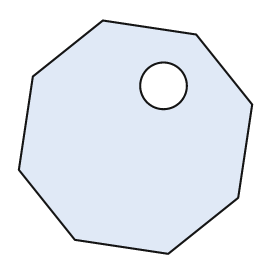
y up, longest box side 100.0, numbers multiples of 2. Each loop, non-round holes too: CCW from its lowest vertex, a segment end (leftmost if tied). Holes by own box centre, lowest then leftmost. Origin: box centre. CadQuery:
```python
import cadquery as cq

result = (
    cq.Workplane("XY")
    .moveTo(14.0, -50.0)
    .lineTo(44.0, -26.0)
    .lineTo(50.0, 14.0)
    .lineTo(26.0, 44.0)
    .lineTo(-14.0, 50.0)
    .lineTo(-44.0, 26.0)
    .lineTo(-50.0, -14.0)
    .lineTo(-26.0, -44.0)
    .close()
    .moveTo(12.0, 22.0)
    .circle(10.0)
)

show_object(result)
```